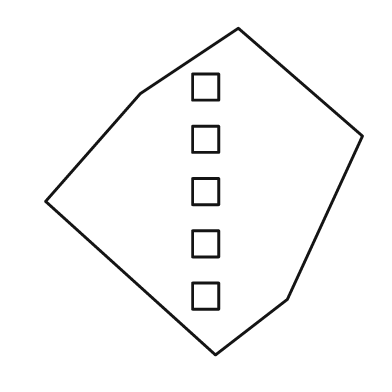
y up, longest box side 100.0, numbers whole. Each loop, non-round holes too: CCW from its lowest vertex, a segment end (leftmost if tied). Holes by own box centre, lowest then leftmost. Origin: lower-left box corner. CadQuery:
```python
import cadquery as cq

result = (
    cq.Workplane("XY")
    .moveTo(52.0, 0.0)
    .lineTo(74.0, 17.0)
    .lineTo(97.0, 67.0)
    .lineTo(59.0, 100.0)
    .lineTo(29.0, 80.0)
    .lineTo(0.0, 47.0)
    .close()
    .moveTo(45.0, 14.0)
    .lineTo(53.0, 14.0)
    .lineTo(53.0, 22.0)
    .lineTo(45.0, 22.0)
    .close()
    .moveTo(45.0, 30.0)
    .lineTo(53.0, 30.0)
    .lineTo(53.0, 38.0)
    .lineTo(45.0, 38.0)
    .close()
    .moveTo(45.0, 46.0)
    .lineTo(53.0, 46.0)
    .lineTo(53.0, 54.0)
    .lineTo(45.0, 54.0)
    .close()
    .moveTo(45.0, 62.0)
    .lineTo(53.0, 62.0)
    .lineTo(53.0, 70.0)
    .lineTo(45.0, 70.0)
    .close()
    .moveTo(45.0, 78.0)
    .lineTo(53.0, 78.0)
    .lineTo(53.0, 86.0)
    .lineTo(45.0, 86.0)
    .close()
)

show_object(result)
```